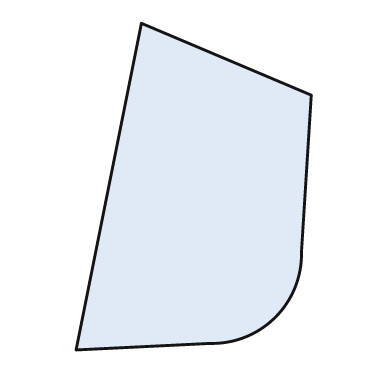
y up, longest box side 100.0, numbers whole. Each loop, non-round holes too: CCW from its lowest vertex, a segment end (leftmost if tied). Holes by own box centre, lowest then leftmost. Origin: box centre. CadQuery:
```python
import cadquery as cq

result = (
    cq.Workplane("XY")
    .moveTo(-36.0, -50.0)
    .lineTo(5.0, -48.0)
    .threePointArc((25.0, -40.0), (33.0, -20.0))
    .lineTo(36.0, 28.0)
    .lineTo(-16.0, 50.0)
    .close()
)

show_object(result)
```